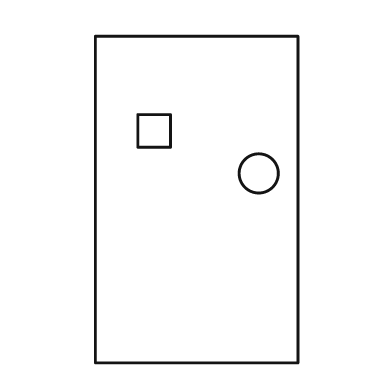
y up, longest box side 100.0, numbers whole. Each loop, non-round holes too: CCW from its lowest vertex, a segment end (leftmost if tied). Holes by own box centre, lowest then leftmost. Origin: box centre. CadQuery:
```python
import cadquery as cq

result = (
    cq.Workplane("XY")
    .moveTo(-31.0, -50.0)
    .lineTo(31.0, -50.0)
    .lineTo(31.0, 50.0)
    .lineTo(-31.0, 50.0)
    .close()
    .moveTo(19.0, 8.0)
    .circle(6.0)
    .moveTo(-18.0, 16.0)
    .lineTo(-8.0, 16.0)
    .lineTo(-8.0, 26.0)
    .lineTo(-18.0, 26.0)
    .close()
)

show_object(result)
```